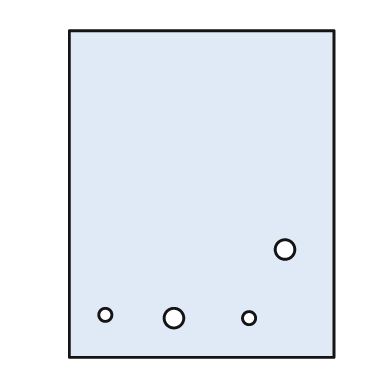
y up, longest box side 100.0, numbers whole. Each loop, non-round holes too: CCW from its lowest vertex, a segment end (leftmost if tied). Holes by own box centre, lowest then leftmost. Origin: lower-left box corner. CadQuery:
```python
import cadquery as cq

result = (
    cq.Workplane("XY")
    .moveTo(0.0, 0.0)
    .lineTo(81.0, 0.0)
    .lineTo(81.0, 100.0)
    .lineTo(0.0, 100.0)
    .close()
    .moveTo(32.0, 12.0)
    .circle(3.0)
    .moveTo(55.0, 12.0)
    .circle(2.0)
    .moveTo(11.0, 13.0)
    .circle(2.0)
    .moveTo(66.0, 33.0)
    .circle(3.0)
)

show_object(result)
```